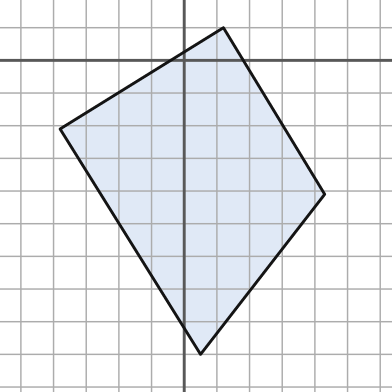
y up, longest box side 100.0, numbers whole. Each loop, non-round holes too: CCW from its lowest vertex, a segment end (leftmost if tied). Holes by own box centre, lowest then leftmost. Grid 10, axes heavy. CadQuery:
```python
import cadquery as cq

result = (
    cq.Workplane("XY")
    .moveTo(5.0, -90.0)
    .lineTo(43.0, -41.0)
    .lineTo(12.0, 10.0)
    .lineTo(-38.0, -21.0)
    .close()
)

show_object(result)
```